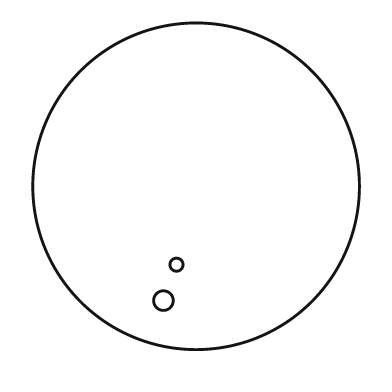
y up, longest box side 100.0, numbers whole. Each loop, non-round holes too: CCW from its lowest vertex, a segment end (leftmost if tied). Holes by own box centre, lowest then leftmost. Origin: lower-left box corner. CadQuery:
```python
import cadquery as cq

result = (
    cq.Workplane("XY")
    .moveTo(50.0, 50.0)
    .circle(50.0)
    .moveTo(40.0, 15.0)
    .circle(3.0)
    .moveTo(44.0, 26.0)
    .circle(2.0)
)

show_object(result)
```